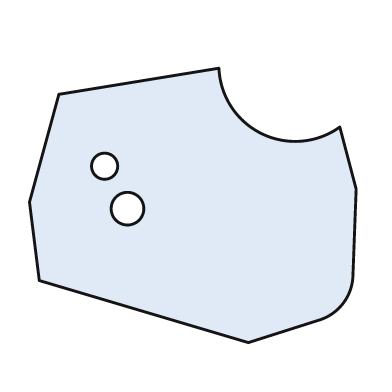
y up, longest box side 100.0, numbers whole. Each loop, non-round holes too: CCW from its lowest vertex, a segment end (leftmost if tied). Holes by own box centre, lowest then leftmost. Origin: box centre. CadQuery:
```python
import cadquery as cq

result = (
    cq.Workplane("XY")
    .moveTo(17.0, -42.0)
    .lineTo(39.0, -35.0)
    .threePointArc((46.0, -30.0), (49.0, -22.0))
    .lineTo(50.0, 5.0)
    .lineTo(45.0, 24.0)
    .threePointArc((21.0, 22.0), (8.0, 42.0))
    .lineTo(-41.0, 34.0)
    .lineTo(-50.0, 1.0)
    .lineTo(-47.0, -23.0)
    .close()
    .moveTo(-20.0, -1.0)
    .circle(5.0)
    .moveTo(-27.0, 12.0)
    .circle(4.0)
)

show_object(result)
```